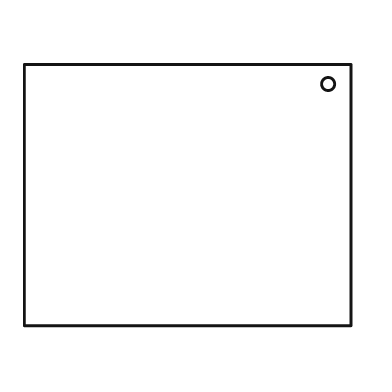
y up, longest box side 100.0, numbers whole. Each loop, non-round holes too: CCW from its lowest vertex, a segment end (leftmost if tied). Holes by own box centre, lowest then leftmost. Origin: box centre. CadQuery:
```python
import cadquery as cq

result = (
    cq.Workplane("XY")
    .moveTo(-50.0, -40.0)
    .lineTo(50.0, -40.0)
    .lineTo(50.0, 40.0)
    .lineTo(-50.0, 40.0)
    .close()
    .moveTo(43.0, 34.0)
    .circle(2.0)
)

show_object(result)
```